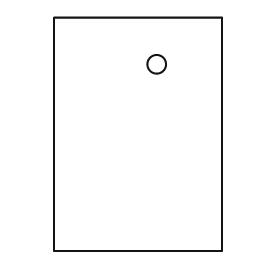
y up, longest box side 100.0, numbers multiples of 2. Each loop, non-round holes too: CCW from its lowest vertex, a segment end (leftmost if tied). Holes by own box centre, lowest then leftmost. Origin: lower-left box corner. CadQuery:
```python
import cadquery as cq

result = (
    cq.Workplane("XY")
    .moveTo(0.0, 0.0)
    .lineTo(72.0, 0.0)
    .lineTo(72.0, 100.0)
    .lineTo(0.0, 100.0)
    .close()
    .moveTo(44.0, 80.0)
    .circle(4.0)
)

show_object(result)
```